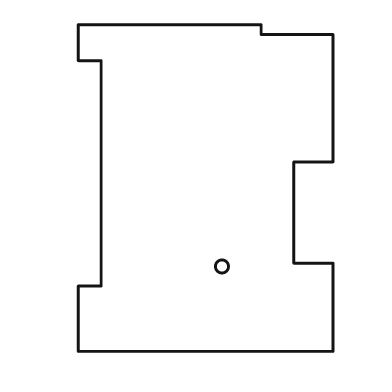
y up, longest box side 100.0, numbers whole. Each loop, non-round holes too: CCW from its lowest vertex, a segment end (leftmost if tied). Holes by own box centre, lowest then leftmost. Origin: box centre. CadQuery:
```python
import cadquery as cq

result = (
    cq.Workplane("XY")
    .moveTo(-39.0, -50.0)
    .lineTo(39.0, -50.0)
    .lineTo(39.0, -23.0)
    .lineTo(27.0, -23.0)
    .lineTo(27.0, 8.0)
    .lineTo(39.0, 8.0)
    .lineTo(39.0, 47.0)
    .lineTo(17.0, 47.0)
    .lineTo(17.0, 50.0)
    .lineTo(-39.0, 50.0)
    .lineTo(-39.0, 39.0)
    .lineTo(-32.0, 39.0)
    .lineTo(-32.0, -30.0)
    .lineTo(-39.0, -30.0)
    .close()
    .moveTo(5.0, -24.0)
    .circle(2.0)
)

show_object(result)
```